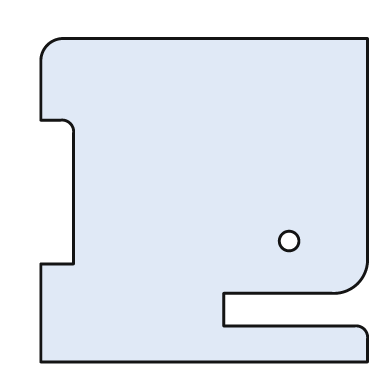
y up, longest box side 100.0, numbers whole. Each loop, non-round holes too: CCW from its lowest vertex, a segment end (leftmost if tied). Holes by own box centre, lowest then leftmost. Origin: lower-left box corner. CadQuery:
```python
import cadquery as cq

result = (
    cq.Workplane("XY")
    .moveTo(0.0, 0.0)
    .lineTo(100.0, 0.0)
    .lineTo(100.0, 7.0)
    .threePointArc((99.0, 10.0), (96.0, 11.0))
    .lineTo(56.0, 11.0)
    .lineTo(56.0, 21.0)
    .lineTo(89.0, 21.0)
    .threePointArc((97.0, 24.0), (100.0, 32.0))
    .lineTo(100.0, 99.0)
    .lineTo(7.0, 99.0)
    .threePointArc((2.0, 97.0), (0.0, 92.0))
    .lineTo(0.0, 74.0)
    .lineTo(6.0, 74.0)
    .threePointArc((9.0, 73.0), (10.0, 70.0))
    .lineTo(10.0, 30.0)
    .lineTo(0.0, 30.0)
    .close()
    .moveTo(76.0, 37.0)
    .circle(3.0)
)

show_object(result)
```